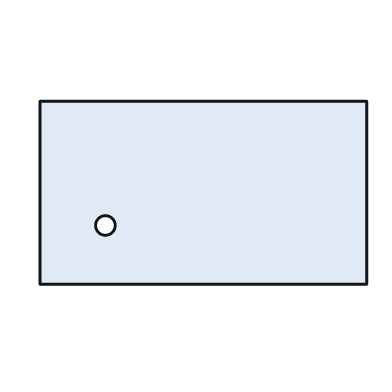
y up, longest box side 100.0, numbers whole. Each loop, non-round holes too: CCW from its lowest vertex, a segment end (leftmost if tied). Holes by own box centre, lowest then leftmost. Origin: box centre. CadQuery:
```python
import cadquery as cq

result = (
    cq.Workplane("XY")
    .moveTo(-50.0, -28.0)
    .lineTo(50.0, -28.0)
    .lineTo(50.0, 28.0)
    .lineTo(-50.0, 28.0)
    .close()
    .moveTo(-30.0, -10.0)
    .circle(3.0)
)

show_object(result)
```